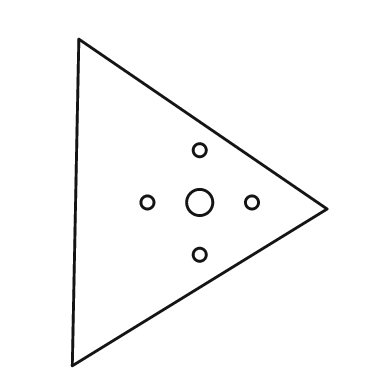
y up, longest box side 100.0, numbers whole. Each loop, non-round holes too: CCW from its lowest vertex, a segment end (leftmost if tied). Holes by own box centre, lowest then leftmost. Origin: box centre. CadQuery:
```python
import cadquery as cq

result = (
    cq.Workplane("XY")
    .moveTo(-39.0, -50.0)
    .lineTo(39.0, -2.0)
    .lineTo(-37.0, 50.0)
    .close()
    .moveTo(0.0, -16.0)
    .circle(2.0)
    .moveTo(-16.0, 0.0)
    .circle(2.0)
    .moveTo(0.0, 0.0)
    .circle(4.0)
    .moveTo(16.0, 0.0)
    .circle(2.0)
    .moveTo(0.0, 16.0)
    .circle(2.0)
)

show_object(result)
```